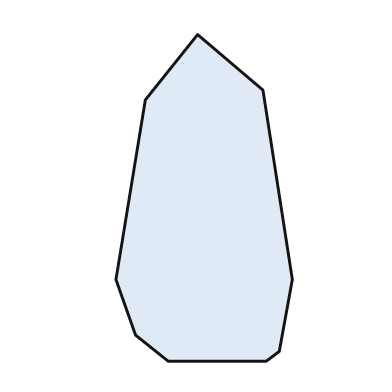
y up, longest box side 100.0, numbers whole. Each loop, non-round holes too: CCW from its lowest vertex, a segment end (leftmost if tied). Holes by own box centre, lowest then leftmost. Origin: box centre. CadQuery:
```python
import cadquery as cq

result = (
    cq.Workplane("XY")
    .moveTo(-11.0, -50.0)
    .lineTo(19.0, -50.0)
    .lineTo(23.0, -47.0)
    .lineTo(27.0, -25.0)
    .lineTo(18.0, 33.0)
    .lineTo(-2.0, 50.0)
    .lineTo(-18.0, 30.0)
    .lineTo(-27.0, -25.0)
    .lineTo(-21.0, -42.0)
    .close()
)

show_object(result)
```